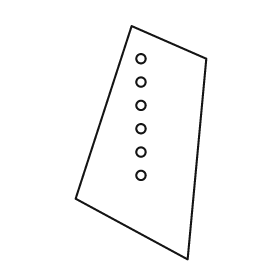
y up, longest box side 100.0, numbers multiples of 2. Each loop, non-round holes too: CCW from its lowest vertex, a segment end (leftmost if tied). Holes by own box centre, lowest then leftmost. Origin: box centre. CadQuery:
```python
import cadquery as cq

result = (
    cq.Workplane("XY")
    .moveTo(20.0, -50.0)
    .lineTo(28.0, 36.0)
    .lineTo(-4.0, 50.0)
    .lineTo(-28.0, -24.0)
    .close()
    .moveTo(0.0, -14.0)
    .circle(2.0)
    .moveTo(0.0, -4.0)
    .circle(2.0)
    .moveTo(0.0, 6.0)
    .circle(2.0)
    .moveTo(0.0, 16.0)
    .circle(2.0)
    .moveTo(0.0, 26.0)
    .circle(2.0)
    .moveTo(0.0, 36.0)
    .circle(2.0)
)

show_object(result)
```